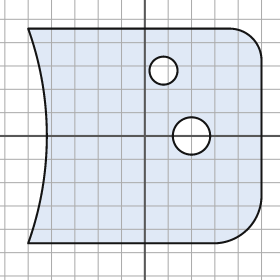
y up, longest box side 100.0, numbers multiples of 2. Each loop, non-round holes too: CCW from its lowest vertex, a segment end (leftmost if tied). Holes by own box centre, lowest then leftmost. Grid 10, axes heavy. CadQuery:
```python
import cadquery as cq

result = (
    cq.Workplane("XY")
    .moveTo(-50.0, -46.0)
    .lineTo(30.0, -46.0)
    .threePointArc((44.0, -40.0), (50.0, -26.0))
    .lineTo(50.0, 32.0)
    .threePointArc((46.0, 42.0), (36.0, 46.0))
    .lineTo(-50.0, 46.0)
    .threePointArc((-42.0, 0.0), (-50.0, -46.0))
    .close()
    .moveTo(20.0, 0.0)
    .circle(8.0)
    .moveTo(8.0, 28.0)
    .circle(6.0)
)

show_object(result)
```